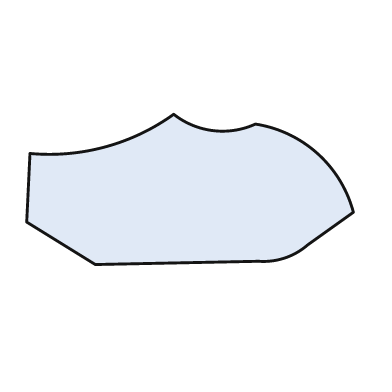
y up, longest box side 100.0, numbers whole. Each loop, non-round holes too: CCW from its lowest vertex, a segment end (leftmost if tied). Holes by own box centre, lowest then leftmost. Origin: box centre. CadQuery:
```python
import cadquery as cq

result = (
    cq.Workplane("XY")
    .moveTo(-29.0, -23.0)
    .lineTo(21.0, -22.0)
    .threePointArc((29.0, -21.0), (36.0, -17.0))
    .lineTo(50.0, -7.0)
    .threePointArc((39.0, 11.0), (20.0, 20.0))
    .threePointArc((7.0, 18.0), (-5.0, 23.0))
    .threePointArc((-26.0, 13.0), (-49.0, 11.0))
    .lineTo(-50.0, -10.0)
    .close()
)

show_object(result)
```